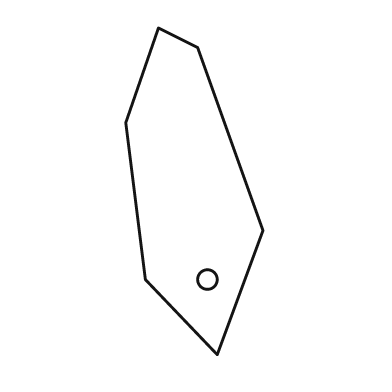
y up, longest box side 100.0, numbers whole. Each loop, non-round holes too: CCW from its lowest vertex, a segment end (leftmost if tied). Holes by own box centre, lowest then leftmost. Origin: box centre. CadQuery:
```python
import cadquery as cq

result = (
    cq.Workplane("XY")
    .moveTo(7.0, -50.0)
    .lineTo(21.0, -12.0)
    .lineTo(1.0, 44.0)
    .lineTo(-11.0, 50.0)
    .lineTo(-21.0, 21.0)
    .lineTo(-15.0, -27.0)
    .close()
    .moveTo(4.0, -27.0)
    .circle(3.0)
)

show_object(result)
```